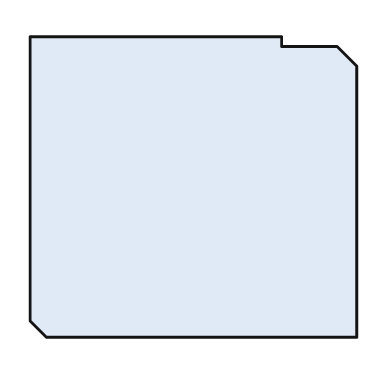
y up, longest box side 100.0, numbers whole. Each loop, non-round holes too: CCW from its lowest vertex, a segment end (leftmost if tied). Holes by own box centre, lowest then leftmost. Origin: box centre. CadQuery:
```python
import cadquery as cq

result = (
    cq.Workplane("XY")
    .moveTo(-45.0, -46.0)
    .lineTo(50.0, -46.0)
    .lineTo(50.0, 37.0)
    .lineTo(44.0, 43.0)
    .lineTo(27.0, 43.0)
    .lineTo(27.0, 46.0)
    .lineTo(-50.0, 46.0)
    .lineTo(-50.0, -41.0)
    .close()
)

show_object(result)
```